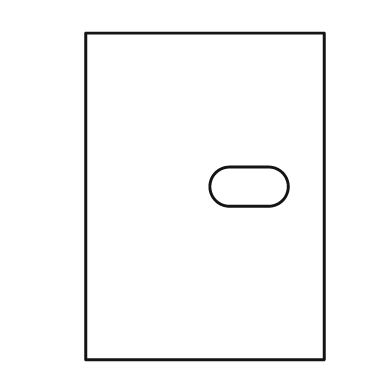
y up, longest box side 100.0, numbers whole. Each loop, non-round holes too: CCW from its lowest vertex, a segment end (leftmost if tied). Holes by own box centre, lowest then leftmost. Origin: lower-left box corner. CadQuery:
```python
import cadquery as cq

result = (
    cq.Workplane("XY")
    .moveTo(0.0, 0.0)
    .lineTo(73.0, 0.0)
    .lineTo(73.0, 100.0)
    .lineTo(0.0, 100.0)
    .close()
    .moveTo(44.0, 47.0)
    .lineTo(56.0, 47.0)
    .threePointArc((62.0, 53.0), (56.0, 59.0))
    .lineTo(44.0, 59.0)
    .threePointArc((38.0, 53.0), (44.0, 47.0))
    .close()
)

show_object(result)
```